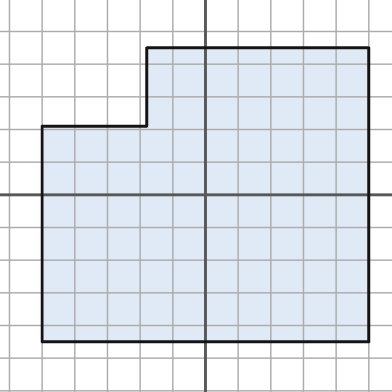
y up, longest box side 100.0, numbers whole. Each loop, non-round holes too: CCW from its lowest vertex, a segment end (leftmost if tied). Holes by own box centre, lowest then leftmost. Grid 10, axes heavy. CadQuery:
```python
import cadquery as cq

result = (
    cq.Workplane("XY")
    .moveTo(-50.0, -45.0)
    .lineTo(50.0, -45.0)
    .lineTo(50.0, 45.0)
    .lineTo(-18.0, 45.0)
    .lineTo(-18.0, 21.0)
    .lineTo(-50.0, 21.0)
    .close()
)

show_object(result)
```